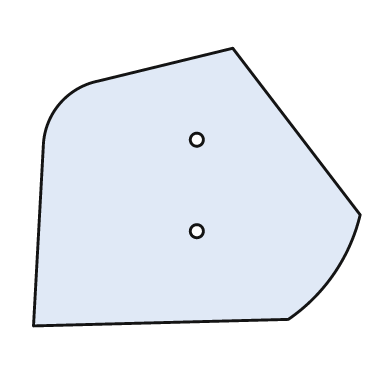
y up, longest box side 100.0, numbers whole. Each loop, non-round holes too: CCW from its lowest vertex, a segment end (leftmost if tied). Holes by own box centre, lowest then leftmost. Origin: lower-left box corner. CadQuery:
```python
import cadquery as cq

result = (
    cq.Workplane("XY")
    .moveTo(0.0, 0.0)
    .lineTo(78.0, 2.0)
    .threePointArc((92.0, 16.0), (100.0, 34.0))
    .lineTo(61.0, 85.0)
    .lineTo(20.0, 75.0)
    .threePointArc((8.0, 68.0), (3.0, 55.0))
    .close()
    .moveTo(50.0, 29.0)
    .circle(2.0)
    .moveTo(50.0, 57.0)
    .circle(2.0)
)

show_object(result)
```